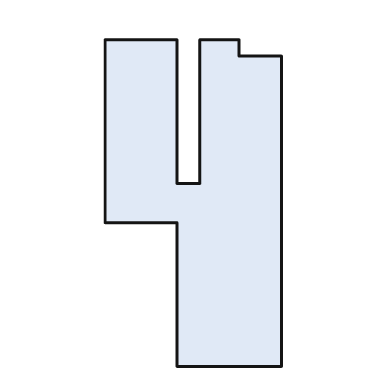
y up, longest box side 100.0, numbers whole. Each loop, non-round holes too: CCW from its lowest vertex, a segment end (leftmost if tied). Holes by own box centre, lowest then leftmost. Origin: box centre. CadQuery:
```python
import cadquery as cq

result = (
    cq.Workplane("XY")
    .moveTo(-5.0, -50.0)
    .lineTo(27.0, -50.0)
    .lineTo(27.0, 45.0)
    .lineTo(14.0, 45.0)
    .lineTo(14.0, 50.0)
    .lineTo(2.0, 50.0)
    .lineTo(2.0, 6.0)
    .lineTo(-5.0, 6.0)
    .lineTo(-5.0, 50.0)
    .lineTo(-27.0, 50.0)
    .lineTo(-27.0, -6.0)
    .lineTo(-5.0, -6.0)
    .close()
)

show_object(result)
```